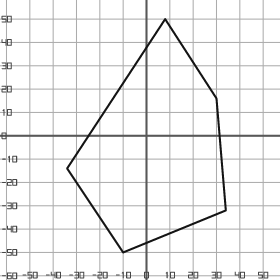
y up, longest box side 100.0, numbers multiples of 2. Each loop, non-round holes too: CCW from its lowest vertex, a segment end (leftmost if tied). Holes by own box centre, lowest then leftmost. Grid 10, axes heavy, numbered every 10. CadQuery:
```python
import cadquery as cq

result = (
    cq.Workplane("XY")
    .moveTo(-10.0, -50.0)
    .lineTo(34.0, -32.0)
    .lineTo(30.0, 16.0)
    .lineTo(8.0, 50.0)
    .lineTo(-34.0, -14.0)
    .close()
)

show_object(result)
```